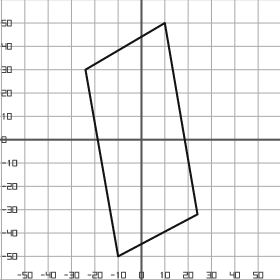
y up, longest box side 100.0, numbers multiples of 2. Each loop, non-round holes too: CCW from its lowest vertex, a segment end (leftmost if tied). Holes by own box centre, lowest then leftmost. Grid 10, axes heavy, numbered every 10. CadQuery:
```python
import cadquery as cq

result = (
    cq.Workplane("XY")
    .moveTo(-10.0, -50.0)
    .lineTo(24.0, -32.0)
    .lineTo(10.0, 50.0)
    .lineTo(-24.0, 30.0)
    .close()
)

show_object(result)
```